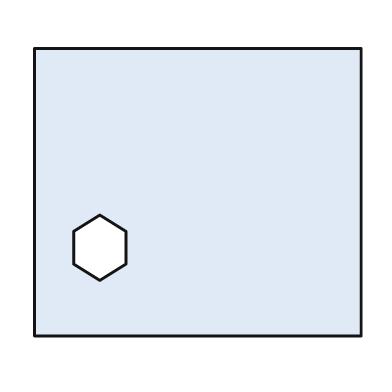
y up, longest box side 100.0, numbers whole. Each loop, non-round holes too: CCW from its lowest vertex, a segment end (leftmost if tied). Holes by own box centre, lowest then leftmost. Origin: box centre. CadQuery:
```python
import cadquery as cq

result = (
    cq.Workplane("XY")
    .moveTo(-50.0, -44.0)
    .lineTo(50.0, -44.0)
    .lineTo(50.0, 44.0)
    .lineTo(-50.0, 44.0)
    .close()
    .moveTo(-30.0, -27.0)
    .lineTo(-22.0, -22.0)
    .lineTo(-22.0, -12.0)
    .lineTo(-30.0, -7.0)
    .lineTo(-38.0, -12.0)
    .lineTo(-38.0, -22.0)
    .close()
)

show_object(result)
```